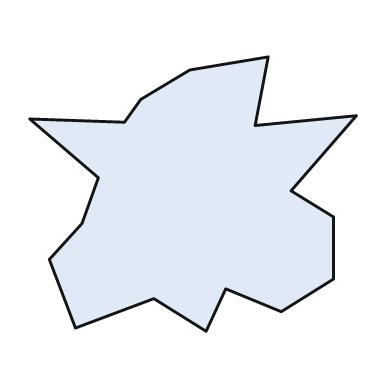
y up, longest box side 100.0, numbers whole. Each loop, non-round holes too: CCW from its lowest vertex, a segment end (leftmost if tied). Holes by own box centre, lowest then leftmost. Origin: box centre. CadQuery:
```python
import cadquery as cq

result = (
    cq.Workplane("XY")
    .moveTo(4.0, -42.0)
    .lineTo(10.0, -29.0)
    .lineTo(27.0, -36.0)
    .lineTo(43.0, -26.0)
    .lineTo(43.0, -7.0)
    .lineTo(30.0, 1.0)
    .lineTo(50.0, 24.0)
    .lineTo(19.0, 21.0)
    .lineTo(23.0, 42.0)
    .lineTo(-1.0, 38.0)
    .lineTo(-16.0, 29.0)
    .lineTo(-21.0, 22.0)
    .lineTo(-50.0, 23.0)
    .lineTo(-29.0, 5.0)
    .lineTo(-34.0, -9.0)
    .lineTo(-44.0, -20.0)
    .lineTo(-36.0, -41.0)
    .lineTo(-12.0, -32.0)
    .close()
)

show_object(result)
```